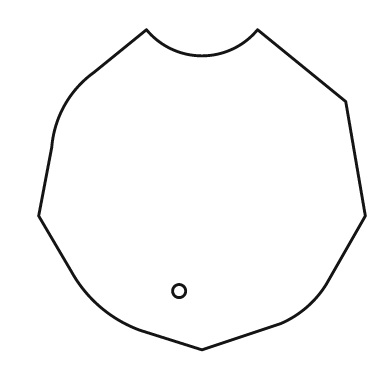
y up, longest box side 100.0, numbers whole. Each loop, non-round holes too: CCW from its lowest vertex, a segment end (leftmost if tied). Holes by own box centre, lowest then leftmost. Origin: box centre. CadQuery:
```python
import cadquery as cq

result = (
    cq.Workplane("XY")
    .moveTo(0.0, -49.0)
    .lineTo(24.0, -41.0)
    .threePointArc((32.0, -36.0), (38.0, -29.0))
    .lineTo(50.0, -8.0)
    .lineTo(44.0, 27.0)
    .lineTo(17.0, 49.0)
    .threePointArc((0.0, 41.0), (-17.0, 49.0))
    .lineTo(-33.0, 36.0)
    .threePointArc((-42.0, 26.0), (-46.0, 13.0))
    .lineTo(-50.0, -8.0)
    .lineTo(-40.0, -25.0)
    .threePointArc((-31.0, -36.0), (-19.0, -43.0))
    .close()
    .moveTo(-7.0, -31.0)
    .circle(2.0)
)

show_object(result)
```